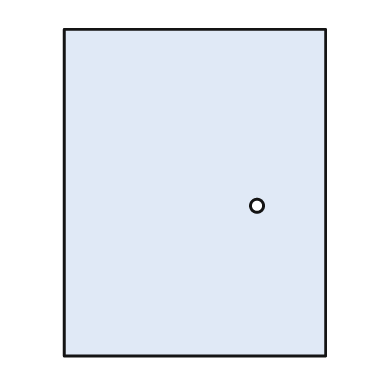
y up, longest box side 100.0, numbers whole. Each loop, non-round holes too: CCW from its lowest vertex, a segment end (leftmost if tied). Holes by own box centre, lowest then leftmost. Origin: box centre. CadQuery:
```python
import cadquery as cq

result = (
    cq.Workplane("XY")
    .moveTo(-40.0, -50.0)
    .lineTo(40.0, -50.0)
    .lineTo(40.0, 50.0)
    .lineTo(-40.0, 50.0)
    .close()
    .moveTo(19.0, -4.0)
    .circle(2.0)
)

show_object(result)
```